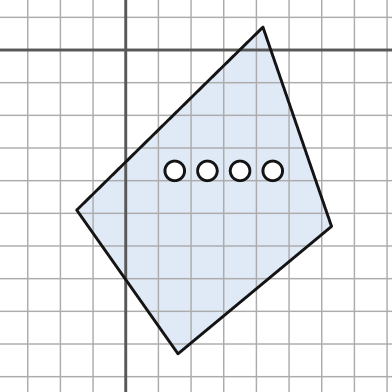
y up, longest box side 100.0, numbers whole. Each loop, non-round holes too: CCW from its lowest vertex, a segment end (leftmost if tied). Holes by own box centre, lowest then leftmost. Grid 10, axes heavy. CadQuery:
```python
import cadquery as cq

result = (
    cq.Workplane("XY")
    .moveTo(16.0, -93.0)
    .lineTo(63.0, -54.0)
    .lineTo(42.0, 7.0)
    .lineTo(-15.0, -49.0)
    .close()
    .moveTo(15.0, -37.0)
    .circle(3.0)
    .moveTo(25.0, -37.0)
    .circle(3.0)
    .moveTo(35.0, -37.0)
    .circle(3.0)
    .moveTo(45.0, -37.0)
    .circle(3.0)
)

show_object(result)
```